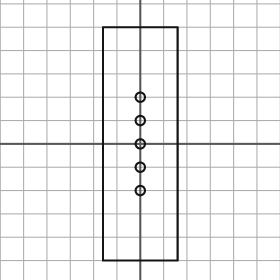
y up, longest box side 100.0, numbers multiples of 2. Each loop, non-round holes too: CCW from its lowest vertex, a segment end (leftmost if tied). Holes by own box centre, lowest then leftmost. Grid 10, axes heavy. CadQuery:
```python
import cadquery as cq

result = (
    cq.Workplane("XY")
    .moveTo(-16.0, -50.0)
    .lineTo(16.0, -50.0)
    .lineTo(16.0, 50.0)
    .lineTo(-16.0, 50.0)
    .close()
    .moveTo(0.0, -20.0)
    .circle(2.0)
    .moveTo(0.0, -10.0)
    .circle(2.0)
    .moveTo(0.0, 0.0)
    .circle(2.0)
    .moveTo(0.0, 10.0)
    .circle(2.0)
    .moveTo(0.0, 20.0)
    .circle(2.0)
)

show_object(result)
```